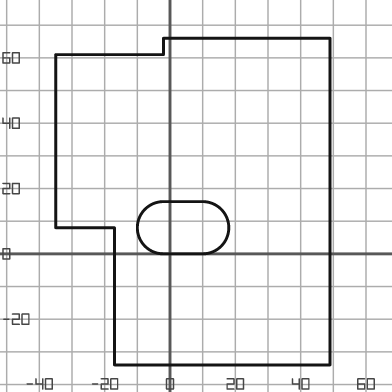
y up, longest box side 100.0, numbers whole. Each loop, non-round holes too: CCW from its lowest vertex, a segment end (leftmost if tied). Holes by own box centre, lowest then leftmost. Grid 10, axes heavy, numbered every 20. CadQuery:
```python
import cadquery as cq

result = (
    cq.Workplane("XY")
    .moveTo(-17.0, -34.0)
    .lineTo(49.0, -34.0)
    .lineTo(49.0, 66.0)
    .lineTo(-2.0, 66.0)
    .lineTo(-2.0, 61.0)
    .lineTo(-35.0, 61.0)
    .lineTo(-35.0, 8.0)
    .lineTo(-17.0, 8.0)
    .close()
    .moveTo(-2.0, 0.0)
    .lineTo(10.0, 0.0)
    .threePointArc((18.0, 8.0), (10.0, 16.0))
    .lineTo(-2.0, 16.0)
    .threePointArc((-10.0, 8.0), (-2.0, 0.0))
    .close()
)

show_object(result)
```